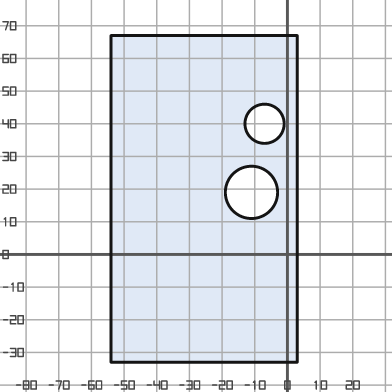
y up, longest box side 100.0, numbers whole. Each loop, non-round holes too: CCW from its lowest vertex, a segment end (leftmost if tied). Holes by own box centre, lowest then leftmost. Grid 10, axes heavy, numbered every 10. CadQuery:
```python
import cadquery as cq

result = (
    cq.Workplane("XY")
    .moveTo(-54.0, -33.0)
    .lineTo(3.0, -33.0)
    .lineTo(3.0, 67.0)
    .lineTo(-54.0, 67.0)
    .close()
    .moveTo(-11.0, 19.0)
    .circle(8.0)
    .moveTo(-7.0, 40.0)
    .circle(6.0)
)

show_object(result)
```